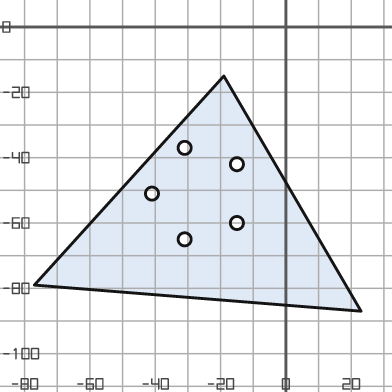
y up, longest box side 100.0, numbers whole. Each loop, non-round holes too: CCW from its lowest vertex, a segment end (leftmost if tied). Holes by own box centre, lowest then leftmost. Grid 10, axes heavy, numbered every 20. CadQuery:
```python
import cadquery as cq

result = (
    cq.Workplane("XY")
    .moveTo(23.0, -87.0)
    .lineTo(-19.0, -15.0)
    .lineTo(-77.0, -79.0)
    .close()
    .moveTo(-31.0, -65.0)
    .circle(2.0)
    .moveTo(-15.0, -60.0)
    .circle(2.0)
    .moveTo(-41.0, -51.0)
    .circle(2.0)
    .moveTo(-15.0, -42.0)
    .circle(2.0)
    .moveTo(-31.0, -37.0)
    .circle(2.0)
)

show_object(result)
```